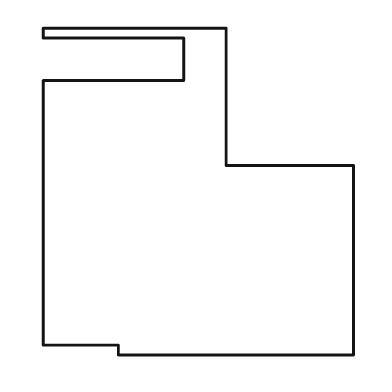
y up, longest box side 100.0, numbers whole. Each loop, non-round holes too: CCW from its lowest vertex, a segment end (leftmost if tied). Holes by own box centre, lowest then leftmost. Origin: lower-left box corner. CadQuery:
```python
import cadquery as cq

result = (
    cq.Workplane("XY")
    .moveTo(23.0, 0.0)
    .lineTo(95.0, 0.0)
    .lineTo(95.0, 58.0)
    .lineTo(56.0, 58.0)
    .lineTo(56.0, 100.0)
    .lineTo(0.0, 100.0)
    .lineTo(0.0, 97.0)
    .lineTo(43.0, 97.0)
    .lineTo(43.0, 84.0)
    .lineTo(0.0, 84.0)
    .lineTo(0.0, 3.0)
    .lineTo(23.0, 3.0)
    .close()
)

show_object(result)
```